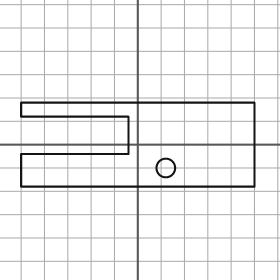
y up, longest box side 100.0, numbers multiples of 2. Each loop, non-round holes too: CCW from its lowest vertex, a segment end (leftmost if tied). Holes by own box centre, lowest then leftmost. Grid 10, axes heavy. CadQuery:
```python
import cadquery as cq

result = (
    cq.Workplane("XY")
    .moveTo(-50.0, -18.0)
    .lineTo(50.0, -18.0)
    .lineTo(50.0, 18.0)
    .lineTo(-50.0, 18.0)
    .lineTo(-50.0, 12.0)
    .lineTo(-4.0, 12.0)
    .lineTo(-4.0, -4.0)
    .lineTo(-50.0, -4.0)
    .close()
    .moveTo(12.0, -10.0)
    .circle(4.0)
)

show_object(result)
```